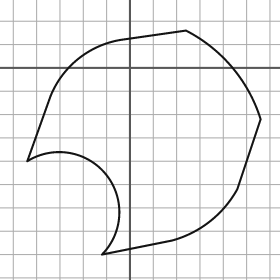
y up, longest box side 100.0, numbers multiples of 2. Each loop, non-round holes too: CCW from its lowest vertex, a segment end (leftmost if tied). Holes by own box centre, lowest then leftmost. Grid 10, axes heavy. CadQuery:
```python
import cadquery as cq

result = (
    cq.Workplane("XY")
    .moveTo(-12.0, -80.0)
    .lineTo(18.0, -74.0)
    .threePointArc((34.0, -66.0), (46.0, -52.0))
    .lineTo(56.0, -22.0)
    .threePointArc((44.0, 0.0), (24.0, 16.0))
    .lineTo(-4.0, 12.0)
    .threePointArc((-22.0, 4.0), (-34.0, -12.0))
    .lineTo(-44.0, -40.0)
    .threePointArc((-10.0, -46.0), (-12.0, -80.0))
    .close()
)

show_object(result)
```